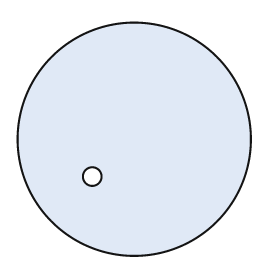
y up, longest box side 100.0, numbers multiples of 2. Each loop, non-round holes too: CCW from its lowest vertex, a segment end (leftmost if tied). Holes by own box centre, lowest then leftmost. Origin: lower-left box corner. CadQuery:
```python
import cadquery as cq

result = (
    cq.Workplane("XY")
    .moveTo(50.0, 50.0)
    .circle(50.0)
    .moveTo(32.0, 34.0)
    .circle(4.0)
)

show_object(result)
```